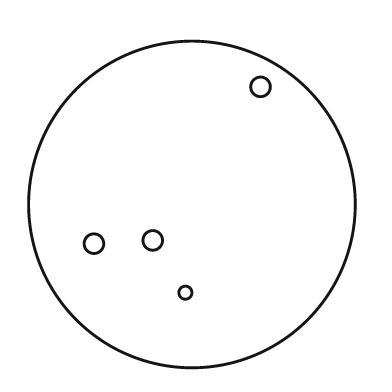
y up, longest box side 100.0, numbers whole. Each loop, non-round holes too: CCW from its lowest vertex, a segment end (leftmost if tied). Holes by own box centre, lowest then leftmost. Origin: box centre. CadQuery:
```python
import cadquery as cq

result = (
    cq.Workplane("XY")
    .moveTo(0.0, 0.0)
    .circle(50.0)
    .moveTo(-2.0, -27.0)
    .circle(2.0)
    .moveTo(-30.0, -12.0)
    .circle(3.0)
    .moveTo(-12.0, -11.0)
    .circle(3.0)
    .moveTo(21.0, 36.0)
    .circle(3.0)
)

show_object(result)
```